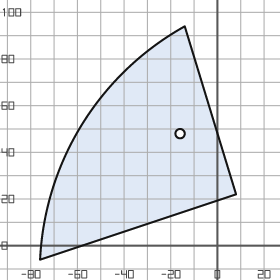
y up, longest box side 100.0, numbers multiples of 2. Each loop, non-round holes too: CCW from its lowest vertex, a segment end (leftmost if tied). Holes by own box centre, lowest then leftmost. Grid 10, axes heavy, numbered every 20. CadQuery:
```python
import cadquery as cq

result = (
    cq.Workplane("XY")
    .moveTo(-76.0, -6.0)
    .lineTo(8.0, 22.0)
    .lineTo(-14.0, 94.0)
    .threePointArc((-58.0, 52.0), (-76.0, -6.0))
    .close()
    .moveTo(-16.0, 48.0)
    .circle(2.0)
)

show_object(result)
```